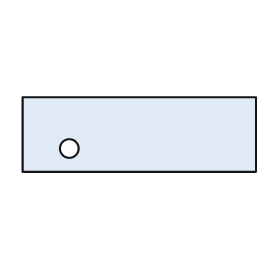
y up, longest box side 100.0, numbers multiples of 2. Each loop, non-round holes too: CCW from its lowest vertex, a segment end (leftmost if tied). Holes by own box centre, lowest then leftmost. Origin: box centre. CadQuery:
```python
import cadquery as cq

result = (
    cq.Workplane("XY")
    .moveTo(-50.0, -16.0)
    .lineTo(50.0, -16.0)
    .lineTo(50.0, 16.0)
    .lineTo(-50.0, 16.0)
    .close()
    .moveTo(-30.0, -6.0)
    .circle(4.0)
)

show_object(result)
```